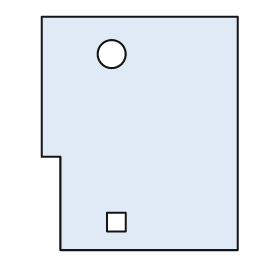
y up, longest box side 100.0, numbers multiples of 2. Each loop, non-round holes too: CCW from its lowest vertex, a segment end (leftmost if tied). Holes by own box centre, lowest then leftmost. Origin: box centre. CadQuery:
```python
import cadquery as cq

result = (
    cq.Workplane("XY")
    .moveTo(-34.0, -50.0)
    .lineTo(42.0, -50.0)
    .lineTo(42.0, 50.0)
    .lineTo(-42.0, 50.0)
    .lineTo(-42.0, -10.0)
    .lineTo(-34.0, -10.0)
    .close()
    .moveTo(-14.0, -42.0)
    .lineTo(-6.0, -42.0)
    .lineTo(-6.0, -34.0)
    .lineTo(-14.0, -34.0)
    .close()
    .moveTo(-12.0, 34.0)
    .circle(6.0)
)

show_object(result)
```